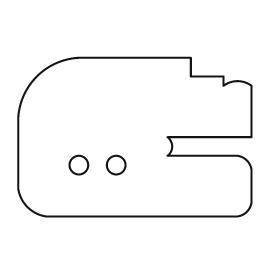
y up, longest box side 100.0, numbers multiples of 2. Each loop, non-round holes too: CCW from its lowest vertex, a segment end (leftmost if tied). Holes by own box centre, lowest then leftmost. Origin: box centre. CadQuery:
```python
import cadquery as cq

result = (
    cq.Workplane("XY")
    .moveTo(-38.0, -34.0)
    .lineTo(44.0, -34.0)
    .threePointArc((48.0, -32.0), (50.0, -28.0))
    .lineTo(50.0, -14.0)
    .threePointArc((48.0, -10.0), (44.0, -8.0))
    .lineTo(14.0, -8.0)
    .threePointArc((16.0, -4.0), (14.0, 0.0))
    .lineTo(50.0, 0.0)
    .lineTo(50.0, 22.0)
    .threePointArc((44.0, 24.0), (38.0, 22.0))
    .lineTo(38.0, 26.0)
    .lineTo(24.0, 26.0)
    .lineTo(24.0, 34.0)
    .lineTo(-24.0, 34.0)
    .threePointArc((-42.0, 26.0), (-50.0, 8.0))
    .lineTo(-50.0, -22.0)
    .threePointArc((-46.0, -30.0), (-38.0, -34.0))
    .close()
    .moveTo(-24.0, -12.0)
    .circle(4.0)
    .moveTo(-8.0, -12.0)
    .circle(4.0)
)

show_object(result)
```